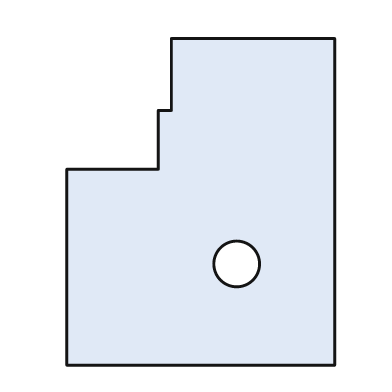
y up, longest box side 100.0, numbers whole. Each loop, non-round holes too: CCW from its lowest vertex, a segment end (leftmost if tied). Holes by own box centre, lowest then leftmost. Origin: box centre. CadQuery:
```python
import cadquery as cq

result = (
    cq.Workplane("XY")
    .moveTo(-41.0, -50.0)
    .lineTo(41.0, -50.0)
    .lineTo(41.0, 50.0)
    .lineTo(-9.0, 50.0)
    .lineTo(-9.0, 28.0)
    .lineTo(-13.0, 28.0)
    .lineTo(-13.0, 10.0)
    .lineTo(-41.0, 10.0)
    .close()
    .moveTo(11.0, -19.0)
    .circle(7.0)
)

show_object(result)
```